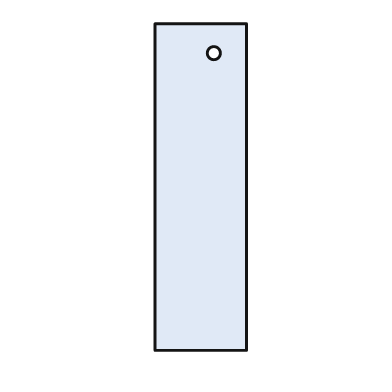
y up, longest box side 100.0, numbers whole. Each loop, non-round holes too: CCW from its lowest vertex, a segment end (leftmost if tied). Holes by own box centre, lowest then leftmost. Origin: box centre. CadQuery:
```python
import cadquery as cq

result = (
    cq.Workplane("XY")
    .moveTo(-14.0, -50.0)
    .lineTo(14.0, -50.0)
    .lineTo(14.0, 50.0)
    .lineTo(-14.0, 50.0)
    .close()
    .moveTo(4.0, 41.0)
    .circle(2.0)
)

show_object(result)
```